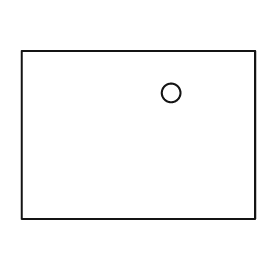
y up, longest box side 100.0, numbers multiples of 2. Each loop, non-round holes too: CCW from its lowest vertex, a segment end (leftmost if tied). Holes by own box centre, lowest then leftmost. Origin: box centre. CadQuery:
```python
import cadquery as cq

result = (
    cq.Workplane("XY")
    .moveTo(-50.0, -36.0)
    .lineTo(50.0, -36.0)
    .lineTo(50.0, 36.0)
    .lineTo(-50.0, 36.0)
    .close()
    .moveTo(14.0, 18.0)
    .circle(4.0)
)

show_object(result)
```